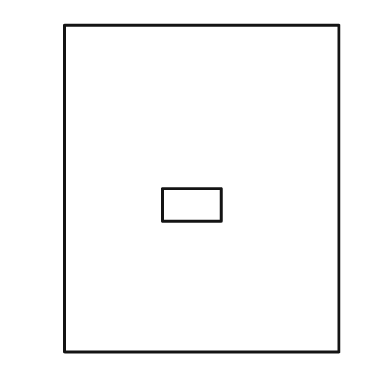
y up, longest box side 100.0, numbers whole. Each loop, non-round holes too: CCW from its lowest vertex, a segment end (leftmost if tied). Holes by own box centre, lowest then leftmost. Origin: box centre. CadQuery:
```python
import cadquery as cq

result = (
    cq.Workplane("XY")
    .moveTo(-42.0, -50.0)
    .lineTo(42.0, -50.0)
    .lineTo(42.0, 50.0)
    .lineTo(-42.0, 50.0)
    .close()
    .moveTo(-12.0, -10.0)
    .lineTo(6.0, -10.0)
    .lineTo(6.0, 0.0)
    .lineTo(-12.0, 0.0)
    .close()
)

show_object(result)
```